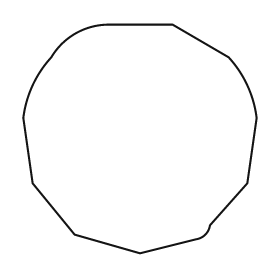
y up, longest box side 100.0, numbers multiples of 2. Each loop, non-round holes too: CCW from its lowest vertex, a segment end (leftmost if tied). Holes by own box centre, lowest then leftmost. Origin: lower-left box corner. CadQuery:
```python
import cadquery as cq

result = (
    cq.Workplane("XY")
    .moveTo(50.0, 0.0)
    .lineTo(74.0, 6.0)
    .threePointArc((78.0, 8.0), (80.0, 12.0))
    .lineTo(96.0, 30.0)
    .lineTo(100.0, 58.0)
    .threePointArc((96.0, 72.0), (88.0, 84.0))
    .lineTo(64.0, 98.0)
    .lineTo(36.0, 98.0)
    .threePointArc((22.0, 94.0), (12.0, 84.0))
    .threePointArc((4.0, 72.0), (0.0, 58.0))
    .lineTo(4.0, 30.0)
    .lineTo(22.0, 8.0)
    .close()
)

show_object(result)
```